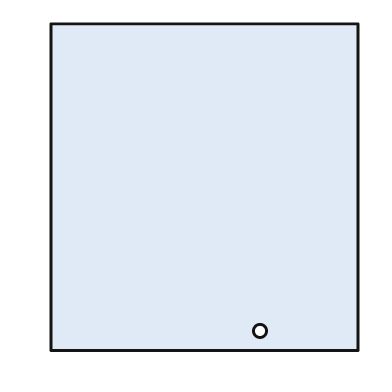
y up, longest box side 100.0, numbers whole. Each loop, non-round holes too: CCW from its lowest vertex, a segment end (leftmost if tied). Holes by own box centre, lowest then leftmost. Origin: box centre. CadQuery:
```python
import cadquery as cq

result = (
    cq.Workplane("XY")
    .moveTo(-47.0, -50.0)
    .lineTo(47.0, -50.0)
    .lineTo(47.0, 50.0)
    .lineTo(-47.0, 50.0)
    .close()
    .moveTo(17.0, -44.0)
    .circle(2.0)
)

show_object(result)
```